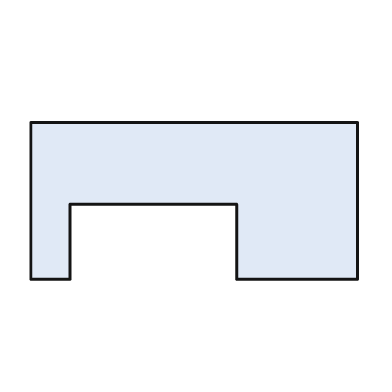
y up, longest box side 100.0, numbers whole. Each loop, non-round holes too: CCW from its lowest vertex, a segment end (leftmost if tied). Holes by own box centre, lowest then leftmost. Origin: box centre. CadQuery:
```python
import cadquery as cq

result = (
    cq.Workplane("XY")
    .moveTo(-50.0, -24.0)
    .lineTo(-38.0, -24.0)
    .lineTo(-38.0, -1.0)
    .lineTo(13.0, -1.0)
    .lineTo(13.0, -24.0)
    .lineTo(50.0, -24.0)
    .lineTo(50.0, 24.0)
    .lineTo(-50.0, 24.0)
    .close()
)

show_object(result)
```